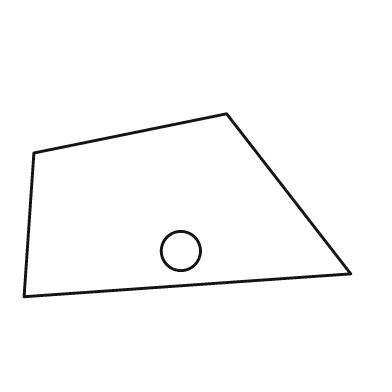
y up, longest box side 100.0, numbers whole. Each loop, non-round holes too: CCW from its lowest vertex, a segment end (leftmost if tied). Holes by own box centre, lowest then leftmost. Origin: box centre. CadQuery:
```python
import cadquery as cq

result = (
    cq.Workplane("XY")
    .moveTo(-50.0, -28.0)
    .lineTo(50.0, -21.0)
    .lineTo(12.0, 28.0)
    .lineTo(-47.0, 16.0)
    .close()
    .moveTo(-2.0, -14.0)
    .circle(6.0)
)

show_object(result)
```